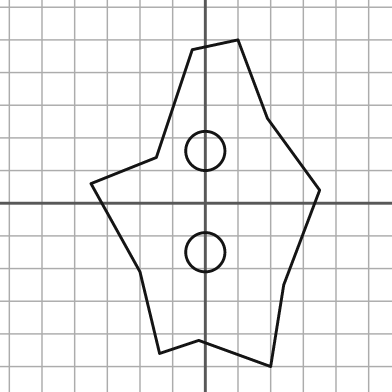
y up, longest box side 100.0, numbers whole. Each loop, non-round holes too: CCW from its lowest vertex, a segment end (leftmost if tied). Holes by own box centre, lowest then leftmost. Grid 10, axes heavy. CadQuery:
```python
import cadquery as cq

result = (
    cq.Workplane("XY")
    .moveTo(20.0, -50.0)
    .lineTo(24.0, -25.0)
    .lineTo(35.0, 4.0)
    .lineTo(19.0, 26.0)
    .lineTo(10.0, 50.0)
    .lineTo(-4.0, 47.0)
    .lineTo(-15.0, 14.0)
    .lineTo(-35.0, 6.0)
    .lineTo(-20.0, -21.0)
    .lineTo(-14.0, -46.0)
    .lineTo(-2.0, -42.0)
    .close()
    .moveTo(0.0, -15.0)
    .circle(6.0)
    .moveTo(0.0, 16.0)
    .circle(6.0)
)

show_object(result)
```